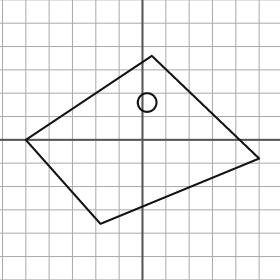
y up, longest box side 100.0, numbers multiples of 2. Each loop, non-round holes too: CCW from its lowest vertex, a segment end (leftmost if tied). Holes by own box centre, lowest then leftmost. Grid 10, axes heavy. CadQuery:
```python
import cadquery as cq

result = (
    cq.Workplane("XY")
    .moveTo(-18.0, -36.0)
    .lineTo(50.0, -8.0)
    .lineTo(4.0, 36.0)
    .lineTo(-50.0, 0.0)
    .close()
    .moveTo(2.0, 16.0)
    .circle(4.0)
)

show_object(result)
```